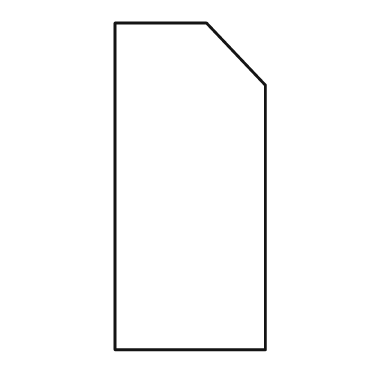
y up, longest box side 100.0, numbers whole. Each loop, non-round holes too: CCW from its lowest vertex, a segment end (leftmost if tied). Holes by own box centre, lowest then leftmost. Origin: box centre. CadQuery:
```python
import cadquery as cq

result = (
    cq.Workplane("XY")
    .moveTo(-23.0, -50.0)
    .lineTo(23.0, -50.0)
    .lineTo(23.0, 31.0)
    .lineTo(5.0, 50.0)
    .lineTo(-23.0, 50.0)
    .close()
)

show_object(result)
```